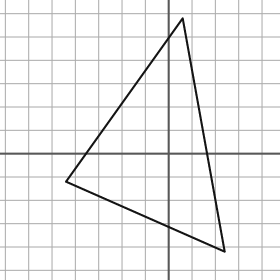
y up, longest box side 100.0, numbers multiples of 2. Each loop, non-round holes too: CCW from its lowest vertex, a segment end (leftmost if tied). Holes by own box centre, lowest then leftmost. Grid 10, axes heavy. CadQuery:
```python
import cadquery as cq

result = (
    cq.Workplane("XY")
    .moveTo(24.0, -42.0)
    .lineTo(6.0, 58.0)
    .lineTo(-44.0, -12.0)
    .close()
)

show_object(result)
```